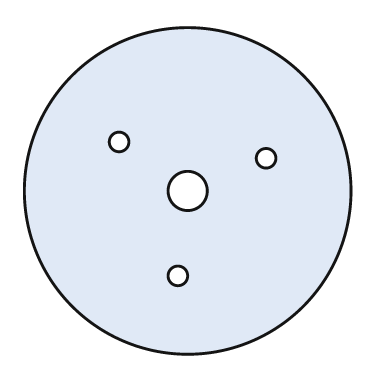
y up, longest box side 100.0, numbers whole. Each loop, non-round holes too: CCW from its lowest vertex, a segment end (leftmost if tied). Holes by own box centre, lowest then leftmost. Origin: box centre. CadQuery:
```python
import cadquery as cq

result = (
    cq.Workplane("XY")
    .moveTo(0.0, 0.0)
    .circle(50.0)
    .moveTo(-3.0, -26.0)
    .circle(3.0)
    .moveTo(0.0, 0.0)
    .circle(6.0)
    .moveTo(24.0, 10.0)
    .circle(3.0)
    .moveTo(-21.0, 15.0)
    .circle(3.0)
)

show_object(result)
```